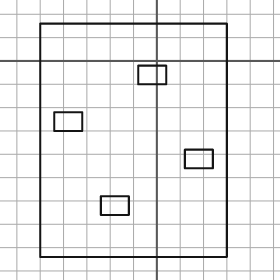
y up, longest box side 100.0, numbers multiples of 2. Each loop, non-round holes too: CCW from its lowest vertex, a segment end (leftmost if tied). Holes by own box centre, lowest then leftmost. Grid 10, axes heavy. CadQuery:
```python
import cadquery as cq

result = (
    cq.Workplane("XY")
    .moveTo(-50.0, -84.0)
    .lineTo(30.0, -84.0)
    .lineTo(30.0, 16.0)
    .lineTo(-50.0, 16.0)
    .close()
    .moveTo(-24.0, -66.0)
    .lineTo(-12.0, -66.0)
    .lineTo(-12.0, -58.0)
    .lineTo(-24.0, -58.0)
    .close()
    .moveTo(12.0, -46.0)
    .lineTo(24.0, -46.0)
    .lineTo(24.0, -38.0)
    .lineTo(12.0, -38.0)
    .close()
    .moveTo(-44.0, -30.0)
    .lineTo(-32.0, -30.0)
    .lineTo(-32.0, -22.0)
    .lineTo(-44.0, -22.0)
    .close()
    .moveTo(-8.0, -10.0)
    .lineTo(4.0, -10.0)
    .lineTo(4.0, -2.0)
    .lineTo(-8.0, -2.0)
    .close()
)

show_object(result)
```